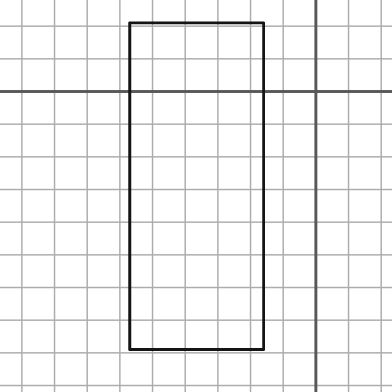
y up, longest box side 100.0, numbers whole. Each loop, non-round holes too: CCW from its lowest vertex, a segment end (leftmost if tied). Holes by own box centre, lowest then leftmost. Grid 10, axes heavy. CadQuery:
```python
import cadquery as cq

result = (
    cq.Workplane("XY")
    .moveTo(-57.0, -79.0)
    .lineTo(-16.0, -79.0)
    .lineTo(-16.0, 21.0)
    .lineTo(-57.0, 21.0)
    .close()
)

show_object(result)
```